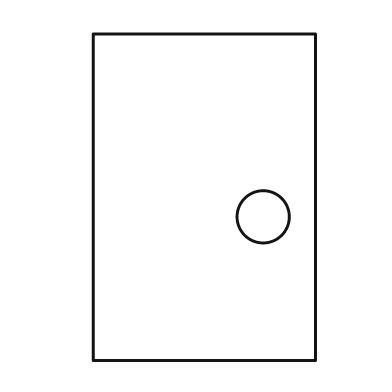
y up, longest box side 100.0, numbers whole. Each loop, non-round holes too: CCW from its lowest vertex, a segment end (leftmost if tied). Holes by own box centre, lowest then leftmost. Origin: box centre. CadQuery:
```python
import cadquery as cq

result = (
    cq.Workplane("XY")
    .moveTo(-34.0, -50.0)
    .lineTo(34.0, -50.0)
    .lineTo(34.0, 50.0)
    .lineTo(-34.0, 50.0)
    .close()
    .moveTo(18.0, -6.0)
    .circle(8.0)
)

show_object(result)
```